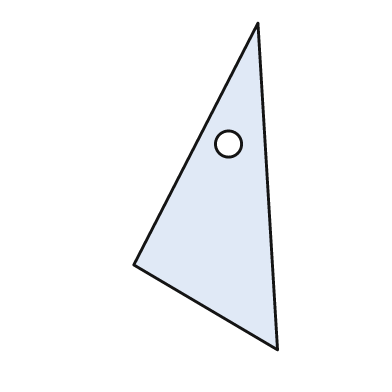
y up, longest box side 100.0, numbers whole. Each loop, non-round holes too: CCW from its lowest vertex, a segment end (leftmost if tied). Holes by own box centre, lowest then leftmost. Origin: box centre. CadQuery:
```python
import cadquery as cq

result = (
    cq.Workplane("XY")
    .moveTo(22.0, -50.0)
    .lineTo(16.0, 50.0)
    .lineTo(-22.0, -24.0)
    .close()
    .moveTo(7.0, 13.0)
    .circle(4.0)
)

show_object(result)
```